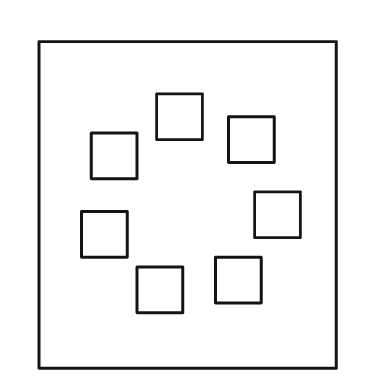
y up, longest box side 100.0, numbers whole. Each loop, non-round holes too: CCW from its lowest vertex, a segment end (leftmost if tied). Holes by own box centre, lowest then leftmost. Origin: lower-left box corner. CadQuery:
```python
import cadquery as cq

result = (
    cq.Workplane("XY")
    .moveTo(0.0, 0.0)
    .lineTo(91.0, 0.0)
    .lineTo(91.0, 100.0)
    .lineTo(0.0, 100.0)
    .close()
    .moveTo(30.0, 17.0)
    .lineTo(44.0, 17.0)
    .lineTo(44.0, 31.0)
    .lineTo(30.0, 31.0)
    .close()
    .moveTo(54.0, 20.0)
    .lineTo(68.0, 20.0)
    .lineTo(68.0, 34.0)
    .lineTo(54.0, 34.0)
    .close()
    .moveTo(13.0, 34.0)
    .lineTo(27.0, 34.0)
    .lineTo(27.0, 48.0)
    .lineTo(13.0, 48.0)
    .close()
    .moveTo(66.0, 40.0)
    .lineTo(80.0, 40.0)
    .lineTo(80.0, 54.0)
    .lineTo(66.0, 54.0)
    .close()
    .moveTo(16.0, 58.0)
    .lineTo(30.0, 58.0)
    .lineTo(30.0, 72.0)
    .lineTo(16.0, 72.0)
    .close()
    .moveTo(58.0, 63.0)
    .lineTo(72.0, 63.0)
    .lineTo(72.0, 77.0)
    .lineTo(58.0, 77.0)
    .close()
    .moveTo(36.0, 70.0)
    .lineTo(50.0, 70.0)
    .lineTo(50.0, 84.0)
    .lineTo(36.0, 84.0)
    .close()
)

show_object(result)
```